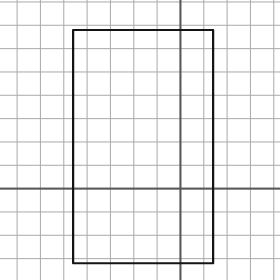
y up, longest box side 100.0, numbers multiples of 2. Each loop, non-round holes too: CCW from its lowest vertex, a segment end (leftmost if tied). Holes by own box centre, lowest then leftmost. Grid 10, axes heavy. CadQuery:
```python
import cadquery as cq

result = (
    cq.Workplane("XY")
    .moveTo(-46.0, -32.0)
    .lineTo(14.0, -32.0)
    .lineTo(14.0, 68.0)
    .lineTo(-46.0, 68.0)
    .close()
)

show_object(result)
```